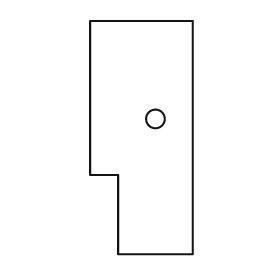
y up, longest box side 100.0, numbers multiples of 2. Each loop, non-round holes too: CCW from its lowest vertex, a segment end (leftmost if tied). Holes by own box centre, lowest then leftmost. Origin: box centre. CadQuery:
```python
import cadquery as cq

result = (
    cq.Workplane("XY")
    .moveTo(-10.0, -50.0)
    .lineTo(22.0, -50.0)
    .lineTo(22.0, 50.0)
    .lineTo(-22.0, 50.0)
    .lineTo(-22.0, -16.0)
    .lineTo(-10.0, -16.0)
    .close()
    .moveTo(6.0, 8.0)
    .circle(4.0)
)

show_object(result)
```